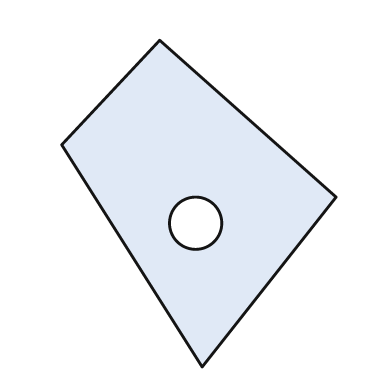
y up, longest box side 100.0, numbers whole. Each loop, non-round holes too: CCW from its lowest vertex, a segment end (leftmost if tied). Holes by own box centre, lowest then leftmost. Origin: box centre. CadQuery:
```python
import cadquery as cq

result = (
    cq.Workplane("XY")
    .moveTo(1.0, -50.0)
    .lineTo(42.0, 2.0)
    .lineTo(-12.0, 50.0)
    .lineTo(-42.0, 18.0)
    .close()
    .moveTo(-1.0, -6.0)
    .circle(8.0)
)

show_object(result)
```